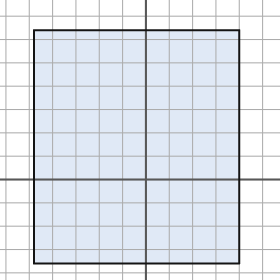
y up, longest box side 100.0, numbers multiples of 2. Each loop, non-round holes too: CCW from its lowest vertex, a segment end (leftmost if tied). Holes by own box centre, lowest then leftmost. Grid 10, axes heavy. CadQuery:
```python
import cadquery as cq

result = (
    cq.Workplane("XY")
    .moveTo(-48.0, -36.0)
    .lineTo(40.0, -36.0)
    .lineTo(40.0, 64.0)
    .lineTo(-48.0, 64.0)
    .close()
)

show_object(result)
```